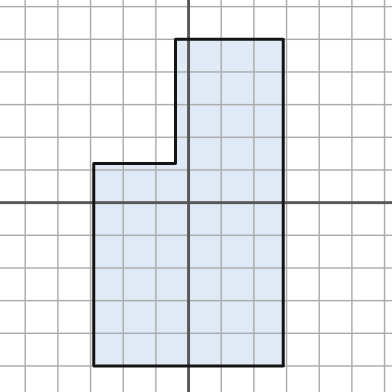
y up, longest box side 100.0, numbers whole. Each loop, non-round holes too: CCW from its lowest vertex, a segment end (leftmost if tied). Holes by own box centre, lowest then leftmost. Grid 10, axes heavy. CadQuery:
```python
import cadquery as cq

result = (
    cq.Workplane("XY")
    .moveTo(-29.0, -50.0)
    .lineTo(29.0, -50.0)
    .lineTo(29.0, 50.0)
    .lineTo(-4.0, 50.0)
    .lineTo(-4.0, 12.0)
    .lineTo(-29.0, 12.0)
    .close()
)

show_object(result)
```